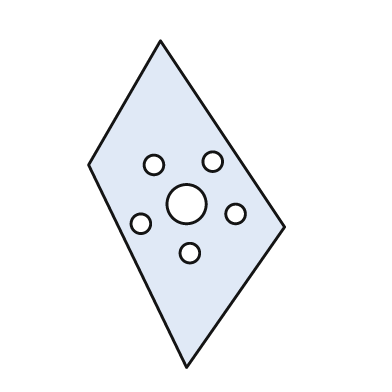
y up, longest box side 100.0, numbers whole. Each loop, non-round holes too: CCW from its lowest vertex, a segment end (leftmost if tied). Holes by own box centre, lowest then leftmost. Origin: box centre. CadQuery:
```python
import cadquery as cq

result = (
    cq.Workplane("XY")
    .moveTo(0.0, -50.0)
    .lineTo(30.0, -7.0)
    .lineTo(-8.0, 50.0)
    .lineTo(-30.0, 12.0)
    .close()
    .moveTo(1.0, -15.0)
    .circle(3.0)
    .moveTo(-14.0, -6.0)
    .circle(3.0)
    .moveTo(15.0, -3.0)
    .circle(3.0)
    .moveTo(0.0, 0.0)
    .circle(6.0)
    .moveTo(-10.0, 12.0)
    .circle(3.0)
    .moveTo(8.0, 13.0)
    .circle(3.0)
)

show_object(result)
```